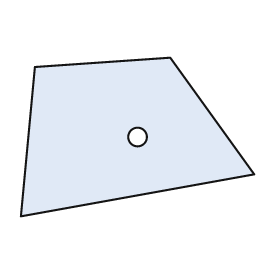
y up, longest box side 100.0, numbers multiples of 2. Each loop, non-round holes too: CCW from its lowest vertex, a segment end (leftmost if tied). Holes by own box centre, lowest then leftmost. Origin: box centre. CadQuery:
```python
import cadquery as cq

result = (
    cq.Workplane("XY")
    .moveTo(-50.0, -34.0)
    .lineTo(50.0, -16.0)
    .lineTo(14.0, 34.0)
    .lineTo(-44.0, 30.0)
    .close()
    .moveTo(0.0, 0.0)
    .circle(4.0)
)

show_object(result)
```